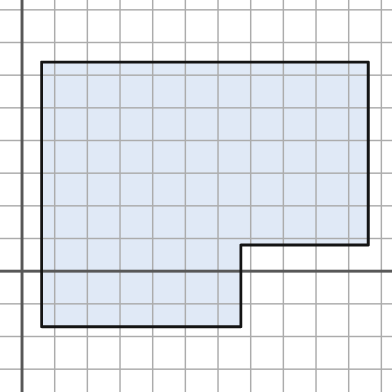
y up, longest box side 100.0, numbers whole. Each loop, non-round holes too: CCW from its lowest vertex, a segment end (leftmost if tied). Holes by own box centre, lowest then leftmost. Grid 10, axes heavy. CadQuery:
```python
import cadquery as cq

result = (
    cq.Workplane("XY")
    .moveTo(6.0, -17.0)
    .lineTo(67.0, -17.0)
    .lineTo(67.0, 8.0)
    .lineTo(106.0, 8.0)
    .lineTo(106.0, 64.0)
    .lineTo(6.0, 64.0)
    .close()
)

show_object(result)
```